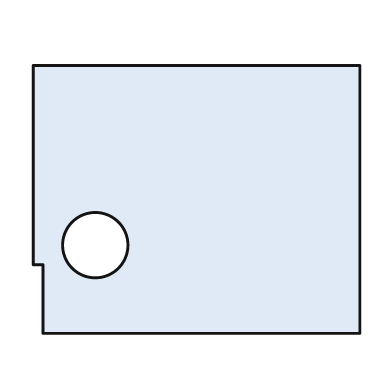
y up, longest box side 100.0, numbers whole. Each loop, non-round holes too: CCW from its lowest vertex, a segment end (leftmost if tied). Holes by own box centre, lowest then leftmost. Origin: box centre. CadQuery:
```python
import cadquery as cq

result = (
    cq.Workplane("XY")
    .moveTo(-47.0, -41.0)
    .lineTo(50.0, -41.0)
    .lineTo(50.0, 41.0)
    .lineTo(-50.0, 41.0)
    .lineTo(-50.0, -20.0)
    .lineTo(-47.0, -20.0)
    .close()
    .moveTo(-31.0, -14.0)
    .circle(10.0)
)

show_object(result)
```